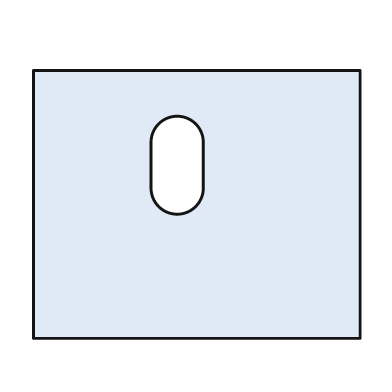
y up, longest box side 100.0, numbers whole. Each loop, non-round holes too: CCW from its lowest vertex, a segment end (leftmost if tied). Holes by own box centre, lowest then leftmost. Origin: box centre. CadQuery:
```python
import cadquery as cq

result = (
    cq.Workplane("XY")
    .moveTo(-50.0, -41.0)
    .lineTo(50.0, -41.0)
    .lineTo(50.0, 41.0)
    .lineTo(-50.0, 41.0)
    .close()
    .moveTo(-14.0, 5.0)
    .threePointArc((-6.0, -3.0), (2.0, 5.0))
    .lineTo(2.0, 19.0)
    .threePointArc((-6.0, 27.0), (-14.0, 19.0))
    .close()
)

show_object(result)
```